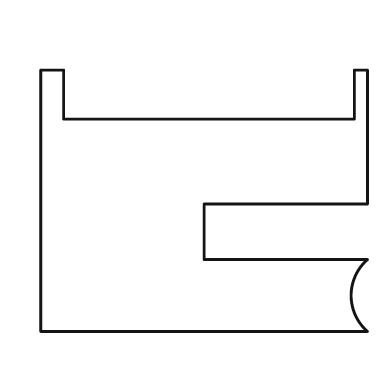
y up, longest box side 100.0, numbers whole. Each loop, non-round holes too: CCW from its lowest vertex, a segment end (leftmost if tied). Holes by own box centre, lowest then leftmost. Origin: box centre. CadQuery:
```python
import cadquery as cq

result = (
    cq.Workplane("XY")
    .moveTo(-50.0, -40.0)
    .lineTo(50.0, -40.0)
    .threePointArc((45.0, -29.0), (50.0, -18.0))
    .lineTo(0.0, -18.0)
    .lineTo(0.0, -1.0)
    .lineTo(50.0, -1.0)
    .lineTo(50.0, 40.0)
    .lineTo(46.0, 40.0)
    .lineTo(46.0, 25.0)
    .lineTo(-43.0, 25.0)
    .lineTo(-43.0, 40.0)
    .lineTo(-50.0, 40.0)
    .close()
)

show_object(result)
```